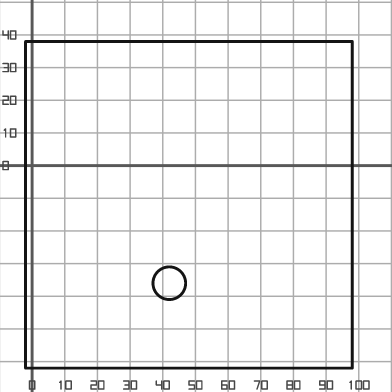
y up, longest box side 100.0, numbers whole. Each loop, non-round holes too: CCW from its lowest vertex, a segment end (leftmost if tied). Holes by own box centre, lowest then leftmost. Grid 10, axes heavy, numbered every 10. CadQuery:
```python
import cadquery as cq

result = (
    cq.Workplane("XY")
    .moveTo(-2.0, -62.0)
    .lineTo(98.0, -62.0)
    .lineTo(98.0, 38.0)
    .lineTo(-2.0, 38.0)
    .close()
    .moveTo(42.0, -36.0)
    .circle(5.0)
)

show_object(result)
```